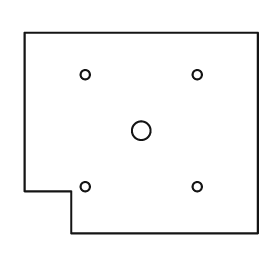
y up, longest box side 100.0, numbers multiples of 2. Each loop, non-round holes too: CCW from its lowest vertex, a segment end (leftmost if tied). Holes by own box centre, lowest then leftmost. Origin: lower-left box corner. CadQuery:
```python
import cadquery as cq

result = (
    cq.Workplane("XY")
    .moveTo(20.0, 0.0)
    .lineTo(100.0, 0.0)
    .lineTo(100.0, 86.0)
    .lineTo(0.0, 86.0)
    .lineTo(0.0, 18.0)
    .lineTo(20.0, 18.0)
    .close()
    .moveTo(26.0, 20.0)
    .circle(2.0)
    .moveTo(74.0, 20.0)
    .circle(2.0)
    .moveTo(50.0, 44.0)
    .circle(4.0)
    .moveTo(26.0, 68.0)
    .circle(2.0)
    .moveTo(74.0, 68.0)
    .circle(2.0)
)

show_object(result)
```